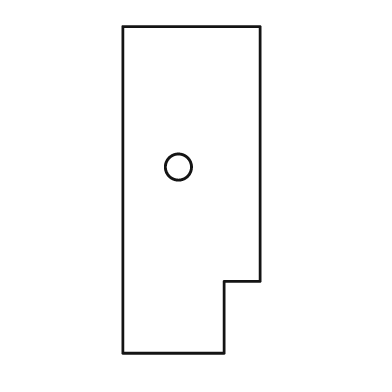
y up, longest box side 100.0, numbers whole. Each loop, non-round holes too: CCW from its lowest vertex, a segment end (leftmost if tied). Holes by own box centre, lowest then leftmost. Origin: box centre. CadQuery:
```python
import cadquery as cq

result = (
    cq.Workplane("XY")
    .moveTo(-21.0, -50.0)
    .lineTo(10.0, -50.0)
    .lineTo(10.0, -28.0)
    .lineTo(21.0, -28.0)
    .lineTo(21.0, 50.0)
    .lineTo(-21.0, 50.0)
    .close()
    .moveTo(-4.0, 7.0)
    .circle(4.0)
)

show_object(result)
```